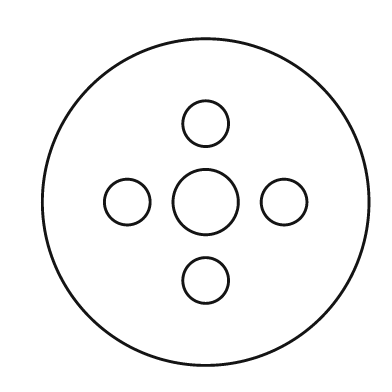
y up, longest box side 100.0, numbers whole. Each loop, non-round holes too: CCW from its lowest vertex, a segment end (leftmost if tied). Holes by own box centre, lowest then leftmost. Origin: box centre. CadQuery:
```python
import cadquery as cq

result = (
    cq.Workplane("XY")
    .moveTo(0.0, 0.0)
    .circle(50.0)
    .moveTo(0.0, -24.0)
    .circle(7.0)
    .moveTo(-24.0, 0.0)
    .circle(7.0)
    .moveTo(0.0, 0.0)
    .circle(10.0)
    .moveTo(24.0, 0.0)
    .circle(7.0)
    .moveTo(0.0, 24.0)
    .circle(7.0)
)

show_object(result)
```